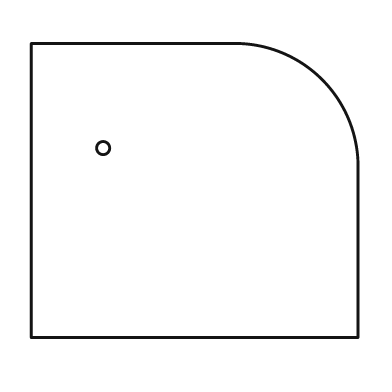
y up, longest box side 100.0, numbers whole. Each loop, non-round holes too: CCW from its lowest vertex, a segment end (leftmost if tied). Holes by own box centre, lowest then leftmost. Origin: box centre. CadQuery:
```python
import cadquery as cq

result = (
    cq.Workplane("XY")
    .moveTo(-50.0, -45.0)
    .lineTo(50.0, -45.0)
    .lineTo(50.0, 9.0)
    .threePointArc((39.0, 34.0), (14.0, 45.0))
    .lineTo(-50.0, 45.0)
    .close()
    .moveTo(-28.0, 13.0)
    .circle(2.0)
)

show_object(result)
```